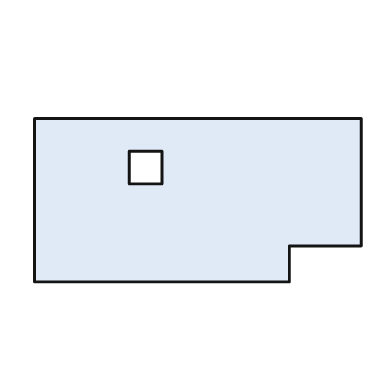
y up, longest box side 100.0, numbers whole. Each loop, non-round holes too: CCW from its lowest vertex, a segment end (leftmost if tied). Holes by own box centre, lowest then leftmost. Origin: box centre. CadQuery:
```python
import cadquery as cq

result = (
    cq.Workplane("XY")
    .moveTo(-50.0, -25.0)
    .lineTo(28.0, -25.0)
    .lineTo(28.0, -14.0)
    .lineTo(50.0, -14.0)
    .lineTo(50.0, 25.0)
    .lineTo(-50.0, 25.0)
    .close()
    .moveTo(-21.0, 5.0)
    .lineTo(-11.0, 5.0)
    .lineTo(-11.0, 15.0)
    .lineTo(-21.0, 15.0)
    .close()
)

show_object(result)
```